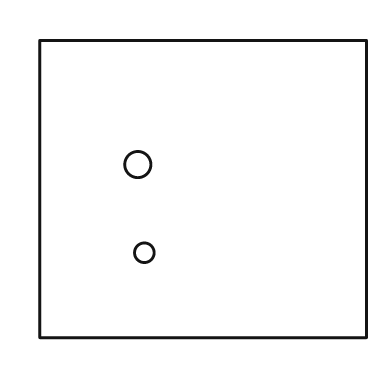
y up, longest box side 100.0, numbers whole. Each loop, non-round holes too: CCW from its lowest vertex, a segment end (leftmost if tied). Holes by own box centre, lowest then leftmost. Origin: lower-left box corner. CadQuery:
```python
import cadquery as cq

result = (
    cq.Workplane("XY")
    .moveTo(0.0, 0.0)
    .lineTo(100.0, 0.0)
    .lineTo(100.0, 91.0)
    .lineTo(0.0, 91.0)
    .close()
    .moveTo(32.0, 26.0)
    .circle(3.0)
    .moveTo(30.0, 53.0)
    .circle(4.0)
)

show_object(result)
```